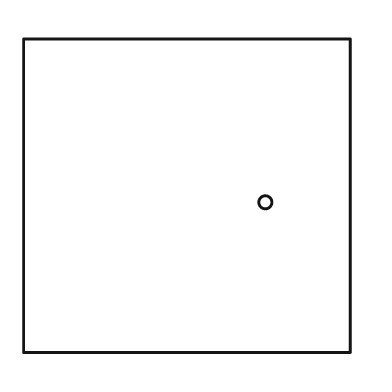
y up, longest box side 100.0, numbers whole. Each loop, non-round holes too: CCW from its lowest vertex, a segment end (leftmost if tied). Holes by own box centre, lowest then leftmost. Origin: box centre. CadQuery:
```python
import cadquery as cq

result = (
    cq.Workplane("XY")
    .moveTo(-50.0, -48.0)
    .lineTo(50.0, -48.0)
    .lineTo(50.0, 48.0)
    .lineTo(-50.0, 48.0)
    .close()
    .moveTo(24.0, -2.0)
    .circle(2.0)
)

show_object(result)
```